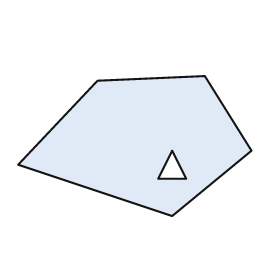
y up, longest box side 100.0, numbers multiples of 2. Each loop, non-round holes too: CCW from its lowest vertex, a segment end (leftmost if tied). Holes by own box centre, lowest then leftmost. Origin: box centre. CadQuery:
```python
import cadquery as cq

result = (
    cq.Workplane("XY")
    .moveTo(16.0, -30.0)
    .lineTo(50.0, -2.0)
    .lineTo(30.0, 30.0)
    .lineTo(-16.0, 28.0)
    .lineTo(-50.0, -8.0)
    .close()
    .moveTo(10.0, -14.0)
    .lineTo(22.0, -14.0)
    .lineTo(16.0, -2.0)
    .close()
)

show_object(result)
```